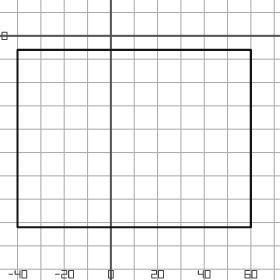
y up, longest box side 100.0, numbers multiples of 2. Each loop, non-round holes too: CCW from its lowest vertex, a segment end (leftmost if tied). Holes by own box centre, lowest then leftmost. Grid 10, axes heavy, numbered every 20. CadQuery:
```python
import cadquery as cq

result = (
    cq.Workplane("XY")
    .moveTo(-40.0, -82.0)
    .lineTo(60.0, -82.0)
    .lineTo(60.0, -6.0)
    .lineTo(-40.0, -6.0)
    .close()
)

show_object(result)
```